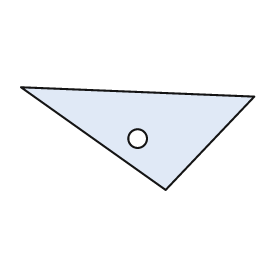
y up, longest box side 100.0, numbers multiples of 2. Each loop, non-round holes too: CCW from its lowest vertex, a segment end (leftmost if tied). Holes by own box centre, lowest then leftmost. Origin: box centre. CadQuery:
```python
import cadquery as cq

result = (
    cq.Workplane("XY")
    .moveTo(12.0, -22.0)
    .lineTo(50.0, 18.0)
    .lineTo(-50.0, 22.0)
    .close()
    .moveTo(0.0, 0.0)
    .circle(4.0)
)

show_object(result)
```